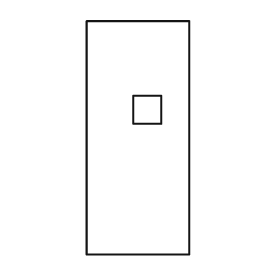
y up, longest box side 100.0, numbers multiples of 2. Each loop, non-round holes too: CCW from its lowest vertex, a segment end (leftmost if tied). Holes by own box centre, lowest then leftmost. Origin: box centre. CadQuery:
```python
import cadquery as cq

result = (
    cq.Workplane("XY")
    .moveTo(-22.0, -50.0)
    .lineTo(22.0, -50.0)
    .lineTo(22.0, 50.0)
    .lineTo(-22.0, 50.0)
    .close()
    .moveTo(-2.0, 6.0)
    .lineTo(10.0, 6.0)
    .lineTo(10.0, 18.0)
    .lineTo(-2.0, 18.0)
    .close()
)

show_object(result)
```